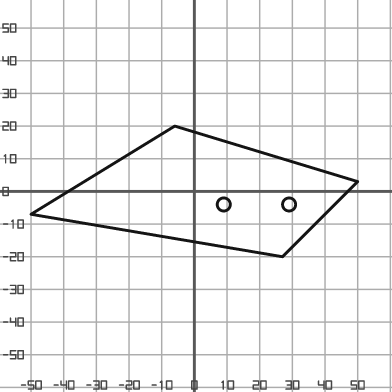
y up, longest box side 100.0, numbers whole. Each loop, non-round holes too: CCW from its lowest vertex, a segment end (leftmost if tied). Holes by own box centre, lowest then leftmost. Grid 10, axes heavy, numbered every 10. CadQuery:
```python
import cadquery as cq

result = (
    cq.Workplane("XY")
    .moveTo(27.0, -20.0)
    .lineTo(50.0, 3.0)
    .lineTo(-6.0, 20.0)
    .lineTo(-50.0, -7.0)
    .close()
    .moveTo(9.0, -4.0)
    .circle(2.0)
    .moveTo(29.0, -4.0)
    .circle(2.0)
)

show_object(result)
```